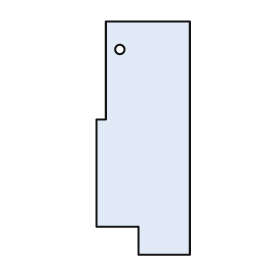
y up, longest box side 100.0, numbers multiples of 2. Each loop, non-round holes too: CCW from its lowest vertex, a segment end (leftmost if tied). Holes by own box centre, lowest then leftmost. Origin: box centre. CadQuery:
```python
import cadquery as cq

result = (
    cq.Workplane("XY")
    .moveTo(-2.0, -50.0)
    .lineTo(20.0, -50.0)
    .lineTo(20.0, 50.0)
    .lineTo(-16.0, 50.0)
    .lineTo(-16.0, 8.0)
    .lineTo(-20.0, 8.0)
    .lineTo(-20.0, -38.0)
    .lineTo(-2.0, -38.0)
    .close()
    .moveTo(-10.0, 38.0)
    .circle(2.0)
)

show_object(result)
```